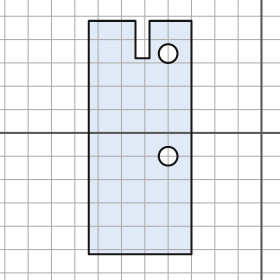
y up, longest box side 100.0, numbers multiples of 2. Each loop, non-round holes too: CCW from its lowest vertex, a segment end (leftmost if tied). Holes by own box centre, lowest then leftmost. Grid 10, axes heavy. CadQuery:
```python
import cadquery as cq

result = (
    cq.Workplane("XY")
    .moveTo(-74.0, -52.0)
    .lineTo(-30.0, -52.0)
    .lineTo(-30.0, 48.0)
    .lineTo(-48.0, 48.0)
    .lineTo(-48.0, 32.0)
    .lineTo(-54.0, 32.0)
    .lineTo(-54.0, 48.0)
    .lineTo(-74.0, 48.0)
    .close()
    .moveTo(-40.0, -10.0)
    .circle(4.0)
    .moveTo(-40.0, 34.0)
    .circle(4.0)
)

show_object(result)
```